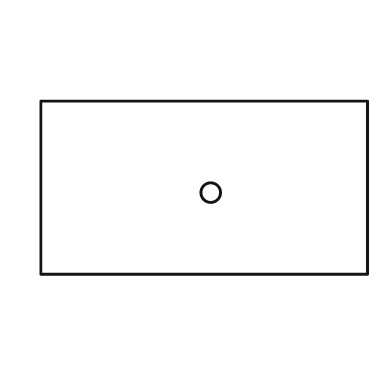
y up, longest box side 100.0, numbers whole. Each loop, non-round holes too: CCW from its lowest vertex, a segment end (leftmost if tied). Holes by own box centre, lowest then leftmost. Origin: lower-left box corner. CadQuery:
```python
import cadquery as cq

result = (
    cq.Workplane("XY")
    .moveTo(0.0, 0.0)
    .lineTo(100.0, 0.0)
    .lineTo(100.0, 53.0)
    .lineTo(0.0, 53.0)
    .close()
    .moveTo(52.0, 25.0)
    .circle(3.0)
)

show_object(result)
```